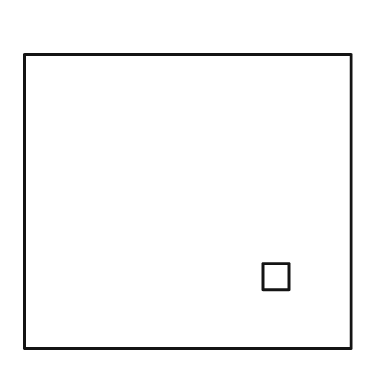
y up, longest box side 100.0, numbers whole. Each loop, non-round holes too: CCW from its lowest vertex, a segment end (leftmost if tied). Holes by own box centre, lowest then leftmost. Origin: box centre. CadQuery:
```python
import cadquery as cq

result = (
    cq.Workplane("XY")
    .moveTo(-50.0, -45.0)
    .lineTo(50.0, -45.0)
    .lineTo(50.0, 45.0)
    .lineTo(-50.0, 45.0)
    .close()
    .moveTo(23.0, -27.0)
    .lineTo(31.0, -27.0)
    .lineTo(31.0, -19.0)
    .lineTo(23.0, -19.0)
    .close()
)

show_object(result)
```